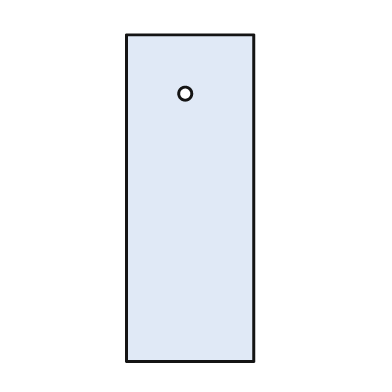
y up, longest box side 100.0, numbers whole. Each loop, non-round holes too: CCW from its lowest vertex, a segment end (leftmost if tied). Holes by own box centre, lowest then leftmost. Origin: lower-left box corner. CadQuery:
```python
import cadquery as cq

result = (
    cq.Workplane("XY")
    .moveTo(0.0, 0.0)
    .lineTo(39.0, 0.0)
    .lineTo(39.0, 100.0)
    .lineTo(0.0, 100.0)
    .close()
    .moveTo(18.0, 82.0)
    .circle(2.0)
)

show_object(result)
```